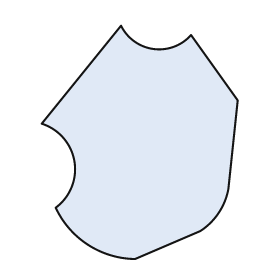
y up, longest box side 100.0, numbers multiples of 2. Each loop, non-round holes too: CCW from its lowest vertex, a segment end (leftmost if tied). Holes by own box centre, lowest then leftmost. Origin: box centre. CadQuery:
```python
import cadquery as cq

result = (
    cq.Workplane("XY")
    .moveTo(-2.0, -50.0)
    .lineTo(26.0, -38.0)
    .threePointArc((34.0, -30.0), (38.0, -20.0))
    .lineTo(42.0, 18.0)
    .lineTo(22.0, 46.0)
    .threePointArc((6.0, 40.0), (-8.0, 50.0))
    .lineTo(-42.0, 8.0)
    .threePointArc((-28.0, -8.0), (-36.0, -28.0))
    .threePointArc((-22.0, -44.0), (-2.0, -50.0))
    .close()
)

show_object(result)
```